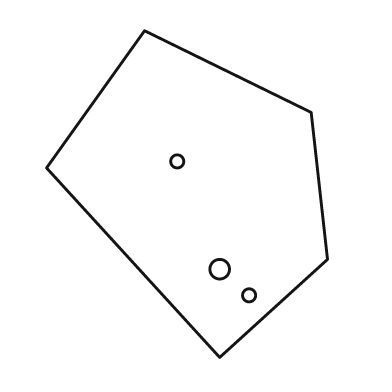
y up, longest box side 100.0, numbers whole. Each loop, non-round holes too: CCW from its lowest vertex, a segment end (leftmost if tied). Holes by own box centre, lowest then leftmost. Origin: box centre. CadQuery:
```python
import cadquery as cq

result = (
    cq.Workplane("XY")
    .moveTo(10.0, -50.0)
    .lineTo(43.0, -20.0)
    .lineTo(38.0, 25.0)
    .lineTo(-13.0, 50.0)
    .lineTo(-43.0, 8.0)
    .close()
    .moveTo(19.0, -31.0)
    .circle(2.0)
    .moveTo(10.0, -23.0)
    .circle(3.0)
    .moveTo(-3.0, 10.0)
    .circle(2.0)
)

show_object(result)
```